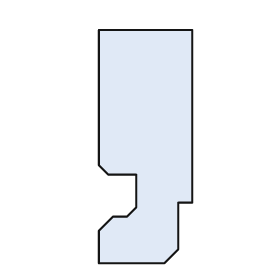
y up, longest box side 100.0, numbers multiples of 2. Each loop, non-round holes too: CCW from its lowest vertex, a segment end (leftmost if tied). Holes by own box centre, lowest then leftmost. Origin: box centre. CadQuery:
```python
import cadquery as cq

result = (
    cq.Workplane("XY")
    .moveTo(-20.0, -50.0)
    .lineTo(8.0, -50.0)
    .lineTo(14.0, -44.0)
    .lineTo(14.0, -24.0)
    .lineTo(20.0, -24.0)
    .lineTo(20.0, 50.0)
    .lineTo(-20.0, 50.0)
    .lineTo(-20.0, -8.0)
    .lineTo(-16.0, -12.0)
    .lineTo(-4.0, -12.0)
    .lineTo(-4.0, -26.0)
    .lineTo(-8.0, -30.0)
    .lineTo(-14.0, -30.0)
    .lineTo(-20.0, -36.0)
    .close()
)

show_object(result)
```